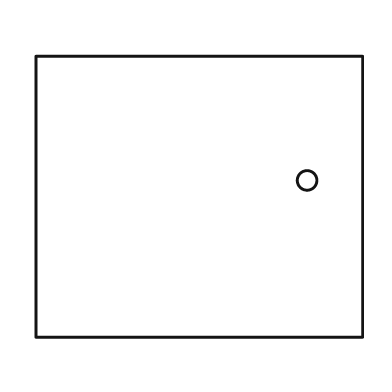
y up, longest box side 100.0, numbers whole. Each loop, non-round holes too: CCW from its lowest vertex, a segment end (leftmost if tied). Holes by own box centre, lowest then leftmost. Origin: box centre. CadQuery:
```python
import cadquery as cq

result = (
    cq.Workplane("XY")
    .moveTo(-50.0, -43.0)
    .lineTo(50.0, -43.0)
    .lineTo(50.0, 43.0)
    .lineTo(-50.0, 43.0)
    .close()
    .moveTo(33.0, 5.0)
    .circle(3.0)
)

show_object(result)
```